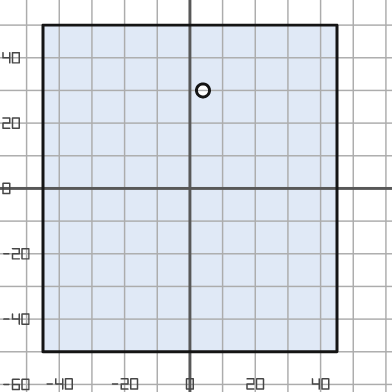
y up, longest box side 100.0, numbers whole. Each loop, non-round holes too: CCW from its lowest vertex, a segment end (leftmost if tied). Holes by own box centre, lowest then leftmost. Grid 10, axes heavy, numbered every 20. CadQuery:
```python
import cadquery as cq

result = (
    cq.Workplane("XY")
    .moveTo(-45.0, -50.0)
    .lineTo(45.0, -50.0)
    .lineTo(45.0, 50.0)
    .lineTo(-45.0, 50.0)
    .close()
    .moveTo(4.0, 30.0)
    .circle(2.0)
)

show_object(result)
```